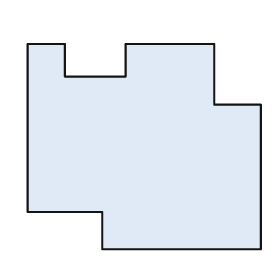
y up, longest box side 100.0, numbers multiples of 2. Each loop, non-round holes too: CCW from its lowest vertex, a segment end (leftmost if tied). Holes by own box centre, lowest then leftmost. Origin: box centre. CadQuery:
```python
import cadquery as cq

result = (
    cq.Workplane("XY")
    .moveTo(-18.0, -44.0)
    .lineTo(50.0, -44.0)
    .lineTo(50.0, 18.0)
    .lineTo(30.0, 18.0)
    .lineTo(30.0, 44.0)
    .lineTo(-8.0, 44.0)
    .lineTo(-8.0, 30.0)
    .lineTo(-34.0, 30.0)
    .lineTo(-34.0, 44.0)
    .lineTo(-50.0, 44.0)
    .lineTo(-50.0, -28.0)
    .lineTo(-18.0, -28.0)
    .close()
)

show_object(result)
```